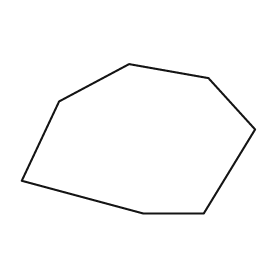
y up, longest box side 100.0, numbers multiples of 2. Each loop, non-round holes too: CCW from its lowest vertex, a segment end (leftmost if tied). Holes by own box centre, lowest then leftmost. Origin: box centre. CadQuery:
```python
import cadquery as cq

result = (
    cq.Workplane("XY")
    .moveTo(2.0, -32.0)
    .lineTo(28.0, -32.0)
    .lineTo(50.0, 4.0)
    .lineTo(30.0, 26.0)
    .lineTo(-4.0, 32.0)
    .lineTo(-34.0, 16.0)
    .lineTo(-50.0, -18.0)
    .close()
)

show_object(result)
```